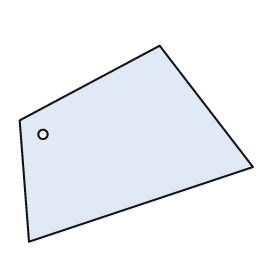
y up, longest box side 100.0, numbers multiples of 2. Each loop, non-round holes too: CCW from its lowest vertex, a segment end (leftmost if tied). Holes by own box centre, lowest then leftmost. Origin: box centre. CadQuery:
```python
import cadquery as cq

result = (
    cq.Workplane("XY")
    .moveTo(-46.0, -42.0)
    .lineTo(50.0, -10.0)
    .lineTo(10.0, 42.0)
    .lineTo(-50.0, 10.0)
    .close()
    .moveTo(-40.0, 4.0)
    .circle(2.0)
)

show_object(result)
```